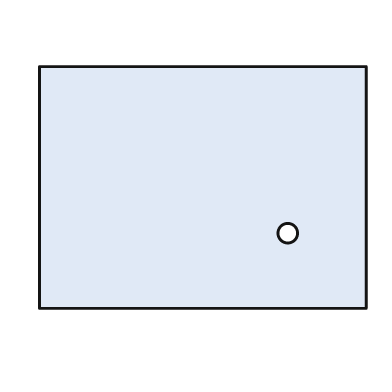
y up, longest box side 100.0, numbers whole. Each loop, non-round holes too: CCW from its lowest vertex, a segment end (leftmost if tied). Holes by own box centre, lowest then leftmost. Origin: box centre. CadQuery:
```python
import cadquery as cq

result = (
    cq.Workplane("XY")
    .moveTo(-50.0, -37.0)
    .lineTo(50.0, -37.0)
    .lineTo(50.0, 37.0)
    .lineTo(-50.0, 37.0)
    .close()
    .moveTo(26.0, -14.0)
    .circle(3.0)
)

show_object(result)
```